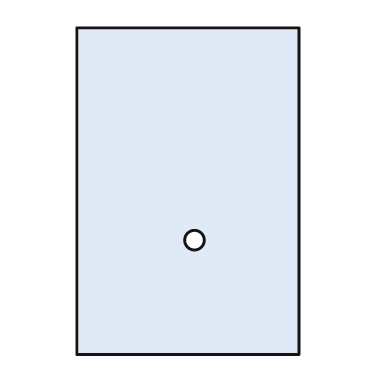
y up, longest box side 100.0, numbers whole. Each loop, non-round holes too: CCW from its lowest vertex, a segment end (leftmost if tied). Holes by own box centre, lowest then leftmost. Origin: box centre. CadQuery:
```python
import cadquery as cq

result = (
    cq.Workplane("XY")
    .moveTo(-34.0, -50.0)
    .lineTo(34.0, -50.0)
    .lineTo(34.0, 50.0)
    .lineTo(-34.0, 50.0)
    .close()
    .moveTo(2.0, -15.0)
    .circle(3.0)
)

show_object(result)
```